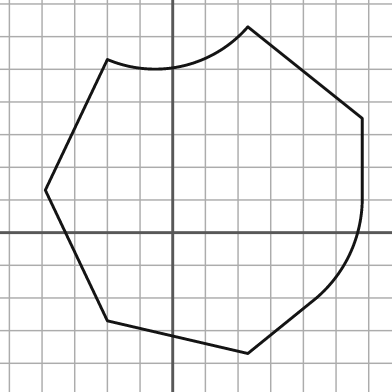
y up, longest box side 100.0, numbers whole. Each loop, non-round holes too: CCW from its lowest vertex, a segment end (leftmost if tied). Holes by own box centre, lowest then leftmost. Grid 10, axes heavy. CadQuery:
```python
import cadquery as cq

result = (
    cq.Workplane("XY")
    .moveTo(23.0, -37.0)
    .lineTo(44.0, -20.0)
    .threePointArc((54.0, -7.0), (58.0, 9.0))
    .lineTo(58.0, 35.0)
    .lineTo(23.0, 63.0)
    .threePointArc((3.0, 51.0), (-20.0, 53.0))
    .lineTo(-39.0, 13.0)
    .lineTo(-20.0, -27.0)
    .close()
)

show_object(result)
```